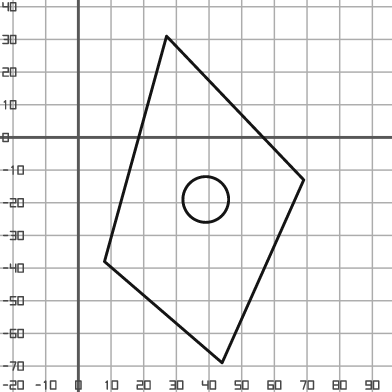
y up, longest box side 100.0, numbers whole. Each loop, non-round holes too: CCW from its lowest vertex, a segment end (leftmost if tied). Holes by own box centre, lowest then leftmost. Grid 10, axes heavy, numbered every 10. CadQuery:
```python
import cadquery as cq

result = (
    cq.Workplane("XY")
    .moveTo(44.0, -69.0)
    .lineTo(69.0, -13.0)
    .lineTo(27.0, 31.0)
    .lineTo(8.0, -38.0)
    .close()
    .moveTo(39.0, -19.0)
    .circle(7.0)
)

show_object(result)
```